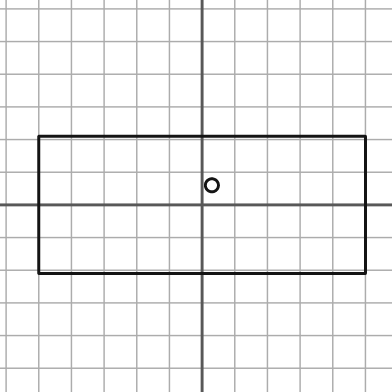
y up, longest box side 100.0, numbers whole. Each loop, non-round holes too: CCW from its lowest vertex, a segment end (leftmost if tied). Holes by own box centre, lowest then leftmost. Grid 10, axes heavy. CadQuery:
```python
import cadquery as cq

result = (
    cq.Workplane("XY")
    .moveTo(-50.0, -21.0)
    .lineTo(50.0, -21.0)
    .lineTo(50.0, 21.0)
    .lineTo(-50.0, 21.0)
    .close()
    .moveTo(3.0, 6.0)
    .circle(2.0)
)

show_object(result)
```